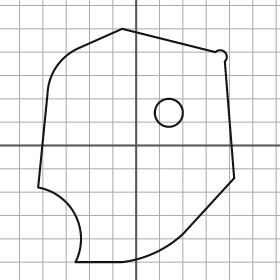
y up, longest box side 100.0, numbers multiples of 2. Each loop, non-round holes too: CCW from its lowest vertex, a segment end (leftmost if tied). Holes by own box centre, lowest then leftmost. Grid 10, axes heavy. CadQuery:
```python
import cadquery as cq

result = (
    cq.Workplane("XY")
    .moveTo(-26.0, -50.0)
    .lineTo(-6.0, -50.0)
    .threePointArc((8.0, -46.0), (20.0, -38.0))
    .lineTo(42.0, -14.0)
    .lineTo(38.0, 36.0)
    .threePointArc((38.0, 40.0), (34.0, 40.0))
    .lineTo(-6.0, 50.0)
    .lineTo(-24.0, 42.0)
    .threePointArc((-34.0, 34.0), (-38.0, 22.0))
    .lineTo(-42.0, -18.0)
    .threePointArc((-26.0, -30.0), (-26.0, -50.0))
    .close()
    .moveTo(14.0, 14.0)
    .circle(6.0)
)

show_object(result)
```